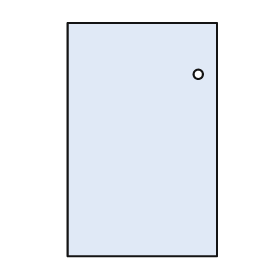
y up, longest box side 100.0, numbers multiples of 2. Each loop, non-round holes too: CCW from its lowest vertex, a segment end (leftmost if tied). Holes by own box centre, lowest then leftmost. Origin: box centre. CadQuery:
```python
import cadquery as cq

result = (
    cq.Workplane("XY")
    .moveTo(-32.0, -50.0)
    .lineTo(32.0, -50.0)
    .lineTo(32.0, 50.0)
    .lineTo(-32.0, 50.0)
    .close()
    .moveTo(24.0, 28.0)
    .circle(2.0)
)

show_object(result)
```